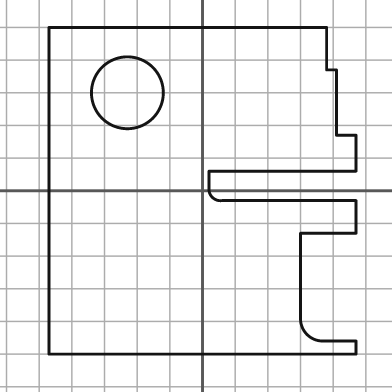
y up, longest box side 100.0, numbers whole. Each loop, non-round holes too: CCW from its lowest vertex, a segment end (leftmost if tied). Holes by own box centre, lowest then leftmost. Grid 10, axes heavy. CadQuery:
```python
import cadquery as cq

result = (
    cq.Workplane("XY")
    .moveTo(-47.0, -50.0)
    .lineTo(47.0, -50.0)
    .lineTo(47.0, -46.0)
    .lineTo(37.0, -46.0)
    .threePointArc((32.0, -44.0), (30.0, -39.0))
    .lineTo(30.0, -13.0)
    .lineTo(47.0, -13.0)
    .lineTo(47.0, -3.0)
    .lineTo(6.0, -3.0)
    .threePointArc((3.0, -2.0), (2.0, 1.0))
    .lineTo(2.0, 6.0)
    .lineTo(47.0, 6.0)
    .lineTo(47.0, 17.0)
    .lineTo(41.0, 17.0)
    .lineTo(41.0, 37.0)
    .lineTo(38.0, 37.0)
    .lineTo(38.0, 50.0)
    .lineTo(-47.0, 50.0)
    .close()
    .moveTo(-23.0, 30.0)
    .circle(11.0)
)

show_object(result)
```